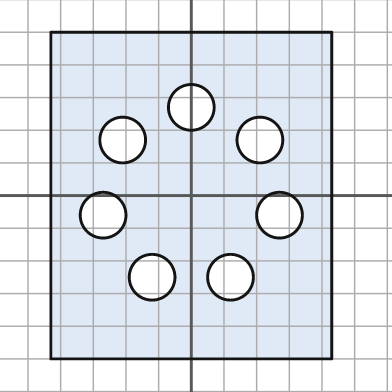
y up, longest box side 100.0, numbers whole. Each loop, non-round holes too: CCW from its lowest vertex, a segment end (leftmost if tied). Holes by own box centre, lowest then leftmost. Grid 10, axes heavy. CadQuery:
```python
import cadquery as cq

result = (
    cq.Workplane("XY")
    .moveTo(-43.0, -50.0)
    .lineTo(43.0, -50.0)
    .lineTo(43.0, 50.0)
    .lineTo(-43.0, 50.0)
    .close()
    .moveTo(-12.0, -25.0)
    .circle(7.0)
    .moveTo(12.0, -25.0)
    .circle(7.0)
    .moveTo(-27.0, -6.0)
    .circle(7.0)
    .moveTo(27.0, -6.0)
    .circle(7.0)
    .moveTo(-21.0, 17.0)
    .circle(7.0)
    .moveTo(21.0, 17.0)
    .circle(7.0)
    .moveTo(0.0, 27.0)
    .circle(7.0)
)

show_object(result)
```